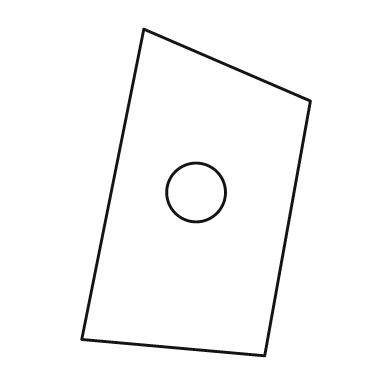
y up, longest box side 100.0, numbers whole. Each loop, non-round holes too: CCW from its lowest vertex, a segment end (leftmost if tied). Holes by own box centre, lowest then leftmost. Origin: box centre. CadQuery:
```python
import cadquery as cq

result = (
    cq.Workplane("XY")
    .moveTo(21.0, -50.0)
    .lineTo(35.0, 28.0)
    .lineTo(-16.0, 50.0)
    .lineTo(-35.0, -45.0)
    .close()
    .moveTo(0.0, 0.0)
    .circle(9.0)
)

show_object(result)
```